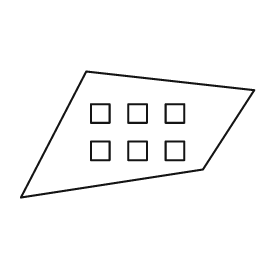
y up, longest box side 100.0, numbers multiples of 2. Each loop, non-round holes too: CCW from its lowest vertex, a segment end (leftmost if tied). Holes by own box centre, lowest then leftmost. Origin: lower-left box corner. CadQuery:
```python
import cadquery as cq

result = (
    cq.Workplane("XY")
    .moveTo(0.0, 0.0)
    .lineTo(78.0, 12.0)
    .lineTo(100.0, 46.0)
    .lineTo(28.0, 54.0)
    .close()
    .moveTo(30.0, 16.0)
    .lineTo(38.0, 16.0)
    .lineTo(38.0, 24.0)
    .lineTo(30.0, 24.0)
    .close()
    .moveTo(46.0, 16.0)
    .lineTo(54.0, 16.0)
    .lineTo(54.0, 24.0)
    .lineTo(46.0, 24.0)
    .close()
    .moveTo(62.0, 16.0)
    .lineTo(70.0, 16.0)
    .lineTo(70.0, 24.0)
    .lineTo(62.0, 24.0)
    .close()
    .moveTo(30.0, 32.0)
    .lineTo(38.0, 32.0)
    .lineTo(38.0, 40.0)
    .lineTo(30.0, 40.0)
    .close()
    .moveTo(46.0, 32.0)
    .lineTo(54.0, 32.0)
    .lineTo(54.0, 40.0)
    .lineTo(46.0, 40.0)
    .close()
    .moveTo(62.0, 32.0)
    .lineTo(70.0, 32.0)
    .lineTo(70.0, 40.0)
    .lineTo(62.0, 40.0)
    .close()
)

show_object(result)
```